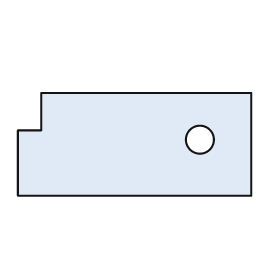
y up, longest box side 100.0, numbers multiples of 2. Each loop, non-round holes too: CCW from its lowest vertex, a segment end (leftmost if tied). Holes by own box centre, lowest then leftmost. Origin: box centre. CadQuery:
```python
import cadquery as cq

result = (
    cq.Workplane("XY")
    .moveTo(-50.0, -22.0)
    .lineTo(50.0, -22.0)
    .lineTo(50.0, 22.0)
    .lineTo(-40.0, 22.0)
    .lineTo(-40.0, 6.0)
    .lineTo(-50.0, 6.0)
    .close()
    .moveTo(28.0, 2.0)
    .circle(6.0)
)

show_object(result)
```